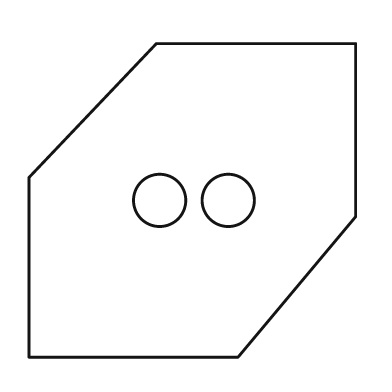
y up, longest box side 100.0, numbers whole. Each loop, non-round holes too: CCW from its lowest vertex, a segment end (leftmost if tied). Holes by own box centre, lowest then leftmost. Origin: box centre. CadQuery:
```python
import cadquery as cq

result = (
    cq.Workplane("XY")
    .moveTo(-50.0, -48.0)
    .lineTo(14.0, -48.0)
    .lineTo(50.0, -5.0)
    .lineTo(50.0, 48.0)
    .lineTo(-11.0, 48.0)
    .lineTo(-50.0, 7.0)
    .close()
    .moveTo(-10.0, 0.0)
    .circle(8.0)
    .moveTo(11.0, 0.0)
    .circle(8.0)
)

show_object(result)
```